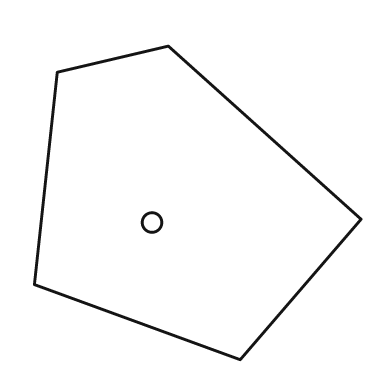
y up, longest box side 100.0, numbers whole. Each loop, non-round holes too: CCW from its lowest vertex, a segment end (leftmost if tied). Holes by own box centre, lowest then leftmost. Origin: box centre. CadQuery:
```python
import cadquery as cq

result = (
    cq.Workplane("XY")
    .moveTo(13.0, -48.0)
    .lineTo(50.0, -5.0)
    .lineTo(-9.0, 48.0)
    .lineTo(-43.0, 40.0)
    .lineTo(-50.0, -25.0)
    .close()
    .moveTo(-14.0, -6.0)
    .circle(3.0)
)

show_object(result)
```